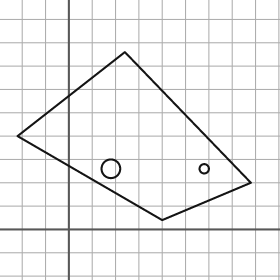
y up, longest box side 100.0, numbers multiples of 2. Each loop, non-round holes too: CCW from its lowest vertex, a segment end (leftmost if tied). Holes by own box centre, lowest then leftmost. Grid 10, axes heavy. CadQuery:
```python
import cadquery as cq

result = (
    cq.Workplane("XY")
    .moveTo(40.0, 4.0)
    .lineTo(78.0, 20.0)
    .lineTo(24.0, 76.0)
    .lineTo(-22.0, 40.0)
    .close()
    .moveTo(18.0, 26.0)
    .circle(4.0)
    .moveTo(58.0, 26.0)
    .circle(2.0)
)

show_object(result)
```